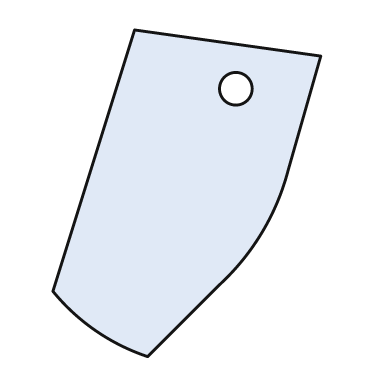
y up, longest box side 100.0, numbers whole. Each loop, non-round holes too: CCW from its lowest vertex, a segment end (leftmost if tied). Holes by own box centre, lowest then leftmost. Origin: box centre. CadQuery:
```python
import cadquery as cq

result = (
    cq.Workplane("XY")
    .moveTo(-12.0, -50.0)
    .lineTo(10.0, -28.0)
    .threePointArc((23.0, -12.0), (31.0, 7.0))
    .lineTo(41.0, 42.0)
    .lineTo(-16.0, 50.0)
    .lineTo(-41.0, -30.0)
    .threePointArc((-28.0, -42.0), (-12.0, -50.0))
    .close()
    .moveTo(15.0, 32.0)
    .circle(5.0)
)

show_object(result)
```